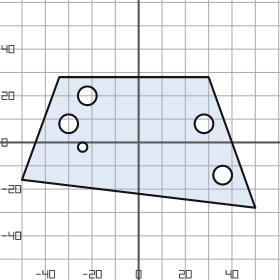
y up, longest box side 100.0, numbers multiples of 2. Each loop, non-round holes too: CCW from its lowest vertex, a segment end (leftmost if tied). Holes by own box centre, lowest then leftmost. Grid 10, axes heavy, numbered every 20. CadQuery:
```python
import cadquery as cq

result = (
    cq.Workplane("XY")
    .moveTo(50.0, -28.0)
    .lineTo(30.0, 28.0)
    .lineTo(-34.0, 28.0)
    .lineTo(-50.0, -16.0)
    .close()
    .moveTo(36.0, -14.0)
    .circle(4.0)
    .moveTo(-24.0, -2.0)
    .circle(2.0)
    .moveTo(-30.0, 8.0)
    .circle(4.0)
    .moveTo(28.0, 8.0)
    .circle(4.0)
    .moveTo(-22.0, 20.0)
    .circle(4.0)
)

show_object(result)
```